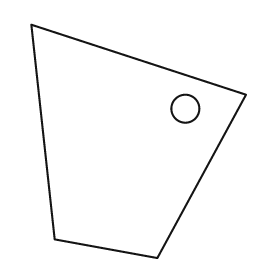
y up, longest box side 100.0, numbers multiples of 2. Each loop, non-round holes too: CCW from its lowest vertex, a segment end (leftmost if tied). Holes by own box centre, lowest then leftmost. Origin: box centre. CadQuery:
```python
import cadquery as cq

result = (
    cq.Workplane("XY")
    .moveTo(8.0, -50.0)
    .lineTo(46.0, 20.0)
    .lineTo(-46.0, 50.0)
    .lineTo(-36.0, -42.0)
    .close()
    .moveTo(20.0, 14.0)
    .circle(6.0)
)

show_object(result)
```